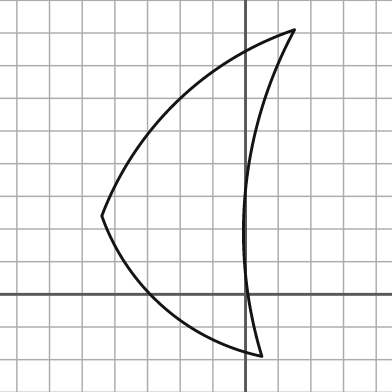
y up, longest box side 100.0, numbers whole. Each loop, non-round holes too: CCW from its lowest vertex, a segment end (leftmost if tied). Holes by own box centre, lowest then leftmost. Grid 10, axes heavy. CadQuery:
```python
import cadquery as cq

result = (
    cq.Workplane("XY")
    .moveTo(5.0, -19.0)
    .threePointArc((0.0, 32.0), (15.0, 81.0))
    .threePointArc((-21.0, 59.0), (-44.0, 24.0))
    .threePointArc((-25.0, -4.0), (5.0, -19.0))
    .close()
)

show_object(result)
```